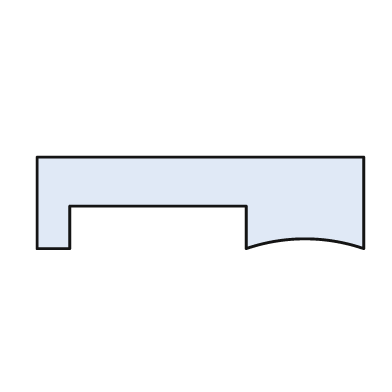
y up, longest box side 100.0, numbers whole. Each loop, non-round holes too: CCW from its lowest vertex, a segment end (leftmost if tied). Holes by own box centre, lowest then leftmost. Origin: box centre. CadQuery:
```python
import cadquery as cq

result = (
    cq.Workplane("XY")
    .moveTo(-50.0, -14.0)
    .lineTo(-40.0, -14.0)
    .lineTo(-40.0, -1.0)
    .lineTo(14.0, -1.0)
    .lineTo(14.0, -14.0)
    .threePointArc((32.0, -11.0), (50.0, -14.0))
    .lineTo(50.0, 14.0)
    .lineTo(-50.0, 14.0)
    .close()
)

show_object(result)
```